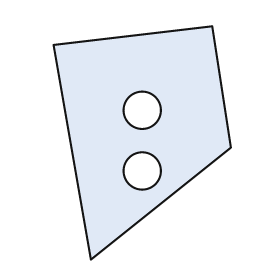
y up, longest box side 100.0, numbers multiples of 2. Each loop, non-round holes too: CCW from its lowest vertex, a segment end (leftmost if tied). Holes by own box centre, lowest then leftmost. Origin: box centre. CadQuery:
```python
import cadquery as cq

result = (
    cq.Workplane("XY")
    .moveTo(-22.0, -50.0)
    .lineTo(38.0, -2.0)
    .lineTo(30.0, 50.0)
    .lineTo(-38.0, 42.0)
    .close()
    .moveTo(0.0, -12.0)
    .circle(8.0)
    .moveTo(0.0, 14.0)
    .circle(8.0)
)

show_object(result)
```